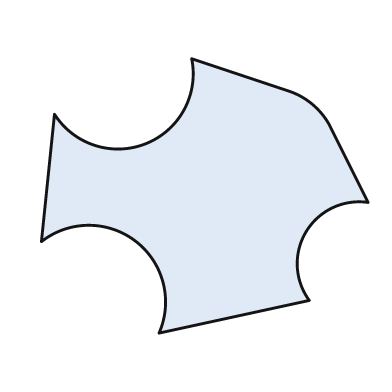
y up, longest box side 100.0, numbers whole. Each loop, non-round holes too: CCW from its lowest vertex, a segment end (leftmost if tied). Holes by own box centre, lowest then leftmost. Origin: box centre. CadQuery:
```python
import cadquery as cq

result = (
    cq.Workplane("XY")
    .moveTo(-14.0, -42.0)
    .lineTo(32.0, -32.0)
    .threePointArc((31.0, -11.0), (50.0, -2.0))
    .lineTo(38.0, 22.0)
    .threePointArc((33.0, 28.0), (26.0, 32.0))
    .lineTo(-4.0, 42.0)
    .threePointArc((-18.0, 16.0), (-46.0, 25.0))
    .lineTo(-50.0, -14.0)
    .threePointArc((-21.0, -14.0), (-14.0, -42.0))
    .close()
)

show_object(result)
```